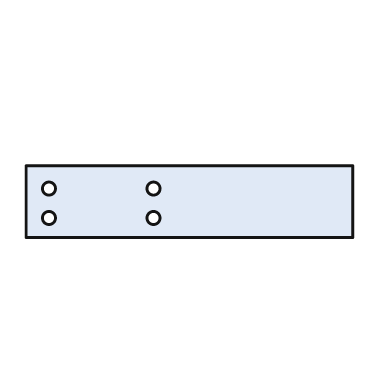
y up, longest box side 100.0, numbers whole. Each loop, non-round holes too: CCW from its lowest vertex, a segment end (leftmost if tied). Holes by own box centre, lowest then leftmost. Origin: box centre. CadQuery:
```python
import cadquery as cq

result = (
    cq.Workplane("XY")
    .moveTo(-50.0, -11.0)
    .lineTo(50.0, -11.0)
    .lineTo(50.0, 11.0)
    .lineTo(-50.0, 11.0)
    .close()
    .moveTo(-43.0, -5.0)
    .circle(2.0)
    .moveTo(-11.0, -5.0)
    .circle(2.0)
    .moveTo(-43.0, 4.0)
    .circle(2.0)
    .moveTo(-11.0, 4.0)
    .circle(2.0)
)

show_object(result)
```